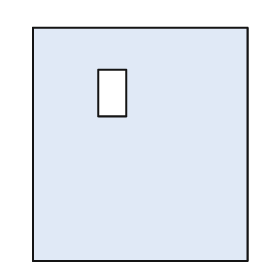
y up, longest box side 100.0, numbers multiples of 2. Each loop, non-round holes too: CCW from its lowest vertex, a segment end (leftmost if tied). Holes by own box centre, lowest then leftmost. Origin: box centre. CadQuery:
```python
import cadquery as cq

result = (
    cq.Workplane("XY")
    .moveTo(-46.0, -50.0)
    .lineTo(46.0, -50.0)
    .lineTo(46.0, 50.0)
    .lineTo(-46.0, 50.0)
    .close()
    .moveTo(-18.0, 12.0)
    .lineTo(-6.0, 12.0)
    .lineTo(-6.0, 32.0)
    .lineTo(-18.0, 32.0)
    .close()
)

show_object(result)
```